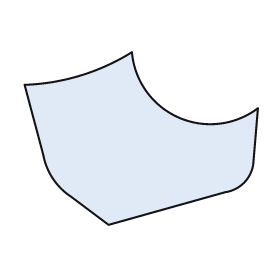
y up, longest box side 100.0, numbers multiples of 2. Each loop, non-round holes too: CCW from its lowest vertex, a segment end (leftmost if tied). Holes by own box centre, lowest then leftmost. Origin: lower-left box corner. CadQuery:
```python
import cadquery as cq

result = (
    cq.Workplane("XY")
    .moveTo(36.0, 0.0)
    .lineTo(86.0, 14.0)
    .threePointArc((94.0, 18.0), (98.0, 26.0))
    .lineTo(100.0, 50.0)
    .threePointArc((66.0, 46.0), (46.0, 74.0))
    .threePointArc((24.0, 64.0), (0.0, 60.0))
    .lineTo(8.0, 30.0)
    .threePointArc((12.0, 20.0), (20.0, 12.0))
    .close()
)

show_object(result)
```